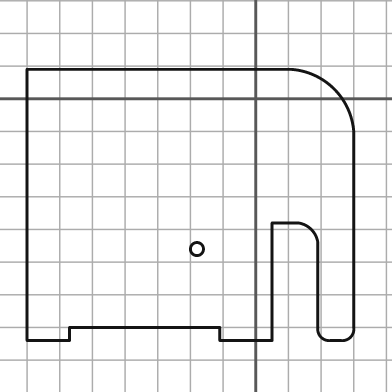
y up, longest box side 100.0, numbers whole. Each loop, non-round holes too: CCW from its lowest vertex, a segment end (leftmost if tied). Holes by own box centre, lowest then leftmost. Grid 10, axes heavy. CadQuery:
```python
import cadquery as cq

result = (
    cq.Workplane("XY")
    .moveTo(-70.0, -74.0)
    .lineTo(-57.0, -74.0)
    .lineTo(-57.0, -70.0)
    .lineTo(-11.0, -70.0)
    .lineTo(-11.0, -74.0)
    .lineTo(5.0, -74.0)
    .lineTo(5.0, -38.0)
    .lineTo(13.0, -38.0)
    .threePointArc((17.0, -40.0), (19.0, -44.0))
    .lineTo(19.0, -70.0)
    .threePointArc((20.0, -73.0), (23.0, -74.0))
    .lineTo(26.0, -74.0)
    .threePointArc((29.0, -73.0), (30.0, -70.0))
    .lineTo(30.0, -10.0)
    .threePointArc((24.0, 3.0), (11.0, 9.0))
    .lineTo(-70.0, 9.0)
    .close()
    .moveTo(-18.0, -46.0)
    .circle(2.0)
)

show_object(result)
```